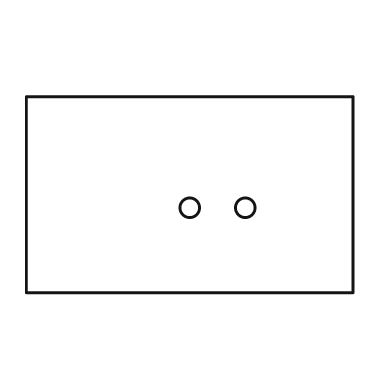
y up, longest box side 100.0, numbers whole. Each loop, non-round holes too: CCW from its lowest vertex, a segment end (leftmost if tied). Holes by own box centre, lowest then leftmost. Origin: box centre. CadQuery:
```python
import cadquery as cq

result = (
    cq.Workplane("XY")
    .moveTo(-50.0, -30.0)
    .lineTo(50.0, -30.0)
    .lineTo(50.0, 30.0)
    .lineTo(-50.0, 30.0)
    .close()
    .moveTo(0.0, -4.0)
    .circle(3.0)
    .moveTo(17.0, -4.0)
    .circle(3.0)
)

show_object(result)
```